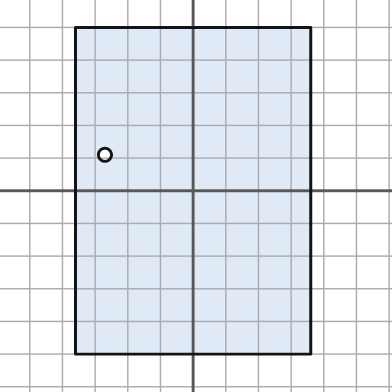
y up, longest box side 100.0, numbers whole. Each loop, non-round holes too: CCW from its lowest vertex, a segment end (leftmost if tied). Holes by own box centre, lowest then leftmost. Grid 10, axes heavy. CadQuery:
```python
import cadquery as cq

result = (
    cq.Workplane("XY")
    .moveTo(-36.0, -50.0)
    .lineTo(36.0, -50.0)
    .lineTo(36.0, 50.0)
    .lineTo(-36.0, 50.0)
    .close()
    .moveTo(-27.0, 11.0)
    .circle(2.0)
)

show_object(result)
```